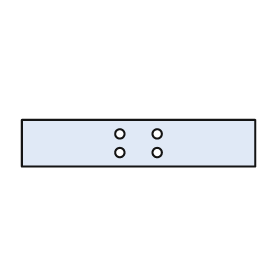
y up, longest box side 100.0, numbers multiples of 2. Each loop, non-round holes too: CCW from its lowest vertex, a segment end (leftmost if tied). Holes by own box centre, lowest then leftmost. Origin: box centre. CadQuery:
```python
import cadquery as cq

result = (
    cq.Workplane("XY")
    .moveTo(-50.0, -10.0)
    .lineTo(50.0, -10.0)
    .lineTo(50.0, 10.0)
    .lineTo(-50.0, 10.0)
    .close()
    .moveTo(-8.0, -4.0)
    .circle(2.0)
    .moveTo(8.0, -4.0)
    .circle(2.0)
    .moveTo(-8.0, 4.0)
    .circle(2.0)
    .moveTo(8.0, 4.0)
    .circle(2.0)
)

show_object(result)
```